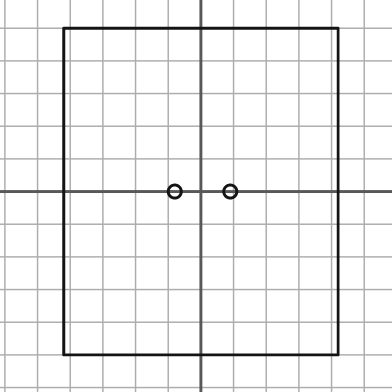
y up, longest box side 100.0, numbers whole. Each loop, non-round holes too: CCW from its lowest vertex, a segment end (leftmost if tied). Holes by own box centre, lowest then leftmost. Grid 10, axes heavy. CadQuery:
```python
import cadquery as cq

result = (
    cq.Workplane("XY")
    .moveTo(-42.0, -50.0)
    .lineTo(42.0, -50.0)
    .lineTo(42.0, 50.0)
    .lineTo(-42.0, 50.0)
    .close()
    .moveTo(-8.0, 0.0)
    .circle(2.0)
    .moveTo(9.0, 0.0)
    .circle(2.0)
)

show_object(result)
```